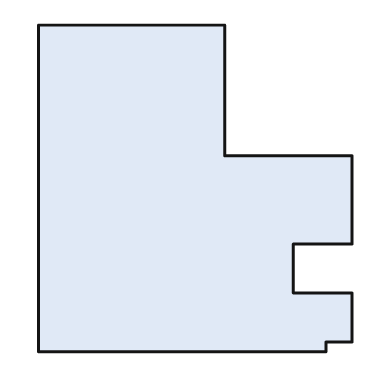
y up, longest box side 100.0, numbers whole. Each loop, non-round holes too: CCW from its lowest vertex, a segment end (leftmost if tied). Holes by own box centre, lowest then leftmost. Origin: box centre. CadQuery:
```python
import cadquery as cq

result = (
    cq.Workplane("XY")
    .moveTo(-48.0, -50.0)
    .lineTo(40.0, -50.0)
    .lineTo(40.0, -47.0)
    .lineTo(48.0, -47.0)
    .lineTo(48.0, -32.0)
    .lineTo(30.0, -32.0)
    .lineTo(30.0, -17.0)
    .lineTo(48.0, -17.0)
    .lineTo(48.0, 10.0)
    .lineTo(9.0, 10.0)
    .lineTo(9.0, 50.0)
    .lineTo(-48.0, 50.0)
    .close()
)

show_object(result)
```